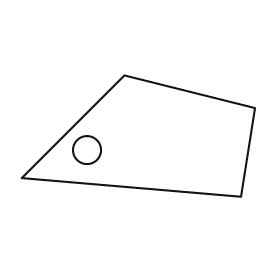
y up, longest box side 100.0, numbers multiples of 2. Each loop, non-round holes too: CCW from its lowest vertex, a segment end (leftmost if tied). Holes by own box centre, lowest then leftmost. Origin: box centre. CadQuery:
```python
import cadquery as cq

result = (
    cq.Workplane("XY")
    .moveTo(44.0, -26.0)
    .lineTo(50.0, 12.0)
    .lineTo(-6.0, 26.0)
    .lineTo(-50.0, -18.0)
    .close()
    .moveTo(-22.0, -6.0)
    .circle(6.0)
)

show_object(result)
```